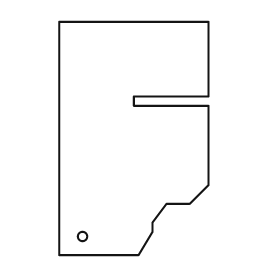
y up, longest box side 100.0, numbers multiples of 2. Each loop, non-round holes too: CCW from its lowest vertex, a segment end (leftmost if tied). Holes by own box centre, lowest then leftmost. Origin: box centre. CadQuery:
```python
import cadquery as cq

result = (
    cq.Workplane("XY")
    .moveTo(-32.0, -50.0)
    .lineTo(2.0, -50.0)
    .lineTo(8.0, -40.0)
    .lineTo(8.0, -36.0)
    .lineTo(14.0, -28.0)
    .lineTo(24.0, -28.0)
    .lineTo(32.0, -20.0)
    .lineTo(32.0, 14.0)
    .lineTo(0.0, 14.0)
    .lineTo(0.0, 18.0)
    .lineTo(32.0, 18.0)
    .lineTo(32.0, 50.0)
    .lineTo(-32.0, 50.0)
    .close()
    .moveTo(-22.0, -42.0)
    .circle(2.0)
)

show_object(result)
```